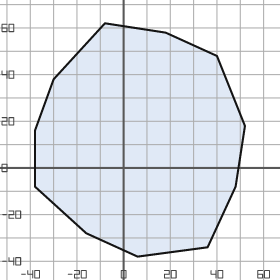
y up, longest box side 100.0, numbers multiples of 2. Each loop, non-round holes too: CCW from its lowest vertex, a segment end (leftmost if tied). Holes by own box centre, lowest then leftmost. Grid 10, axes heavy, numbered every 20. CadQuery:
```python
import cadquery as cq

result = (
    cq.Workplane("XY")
    .moveTo(6.0, -38.0)
    .lineTo(36.0, -34.0)
    .lineTo(48.0, -8.0)
    .lineTo(52.0, 18.0)
    .lineTo(40.0, 48.0)
    .lineTo(18.0, 58.0)
    .lineTo(-8.0, 62.0)
    .lineTo(-30.0, 38.0)
    .lineTo(-38.0, 16.0)
    .lineTo(-38.0, -8.0)
    .lineTo(-16.0, -28.0)
    .close()
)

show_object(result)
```